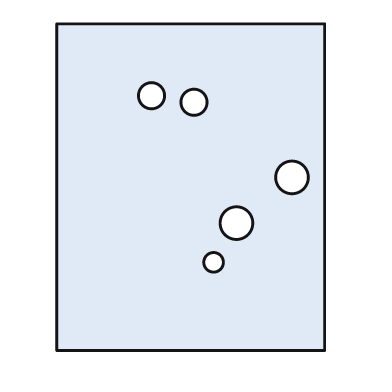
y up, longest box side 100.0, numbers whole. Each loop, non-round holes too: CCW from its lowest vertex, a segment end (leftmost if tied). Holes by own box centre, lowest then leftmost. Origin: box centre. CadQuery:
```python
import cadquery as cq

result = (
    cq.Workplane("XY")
    .moveTo(-41.0, -50.0)
    .lineTo(41.0, -50.0)
    .lineTo(41.0, 50.0)
    .lineTo(-41.0, 50.0)
    .close()
    .moveTo(7.0, -23.0)
    .circle(3.0)
    .moveTo(14.0, -11.0)
    .circle(5.0)
    .moveTo(31.0, 3.0)
    .circle(5.0)
    .moveTo(1.0, 26.0)
    .circle(4.0)
    .moveTo(-12.0, 28.0)
    .circle(4.0)
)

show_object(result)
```